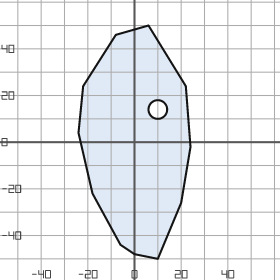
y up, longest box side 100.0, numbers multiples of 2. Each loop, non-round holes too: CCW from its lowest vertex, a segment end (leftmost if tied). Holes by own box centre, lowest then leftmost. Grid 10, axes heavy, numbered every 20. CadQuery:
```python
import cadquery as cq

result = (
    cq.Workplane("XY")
    .moveTo(10.0, -50.0)
    .lineTo(20.0, -26.0)
    .lineTo(24.0, -2.0)
    .lineTo(22.0, 24.0)
    .lineTo(6.0, 50.0)
    .lineTo(-8.0, 46.0)
    .lineTo(-22.0, 24.0)
    .lineTo(-24.0, 4.0)
    .lineTo(-18.0, -22.0)
    .lineTo(-6.0, -44.0)
    .lineTo(0.0, -48.0)
    .close()
    .moveTo(10.0, 14.0)
    .circle(4.0)
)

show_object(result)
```